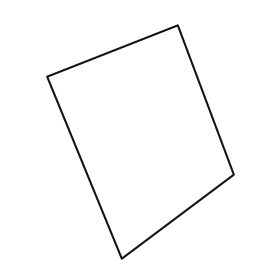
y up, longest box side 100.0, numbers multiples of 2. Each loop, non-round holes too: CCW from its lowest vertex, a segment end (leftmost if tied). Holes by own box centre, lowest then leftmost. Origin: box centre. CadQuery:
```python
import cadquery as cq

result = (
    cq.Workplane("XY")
    .moveTo(-8.0, -50.0)
    .lineTo(40.0, -14.0)
    .lineTo(16.0, 50.0)
    .lineTo(-40.0, 28.0)
    .close()
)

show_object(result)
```